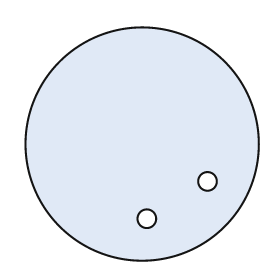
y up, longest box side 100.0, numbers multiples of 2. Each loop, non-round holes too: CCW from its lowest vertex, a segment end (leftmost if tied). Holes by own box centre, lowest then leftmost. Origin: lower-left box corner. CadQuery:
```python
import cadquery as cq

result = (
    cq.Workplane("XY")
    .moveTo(50.0, 50.0)
    .circle(50.0)
    .moveTo(52.0, 18.0)
    .circle(4.0)
    .moveTo(78.0, 34.0)
    .circle(4.0)
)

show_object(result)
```